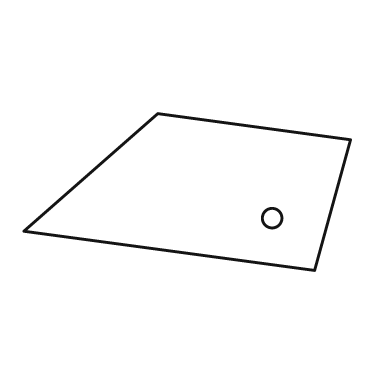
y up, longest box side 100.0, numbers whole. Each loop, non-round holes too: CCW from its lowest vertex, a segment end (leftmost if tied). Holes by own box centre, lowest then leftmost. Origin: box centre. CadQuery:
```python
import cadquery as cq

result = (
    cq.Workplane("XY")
    .moveTo(39.0, -24.0)
    .lineTo(50.0, 16.0)
    .lineTo(-9.0, 24.0)
    .lineTo(-50.0, -12.0)
    .close()
    .moveTo(26.0, -8.0)
    .circle(3.0)
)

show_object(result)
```